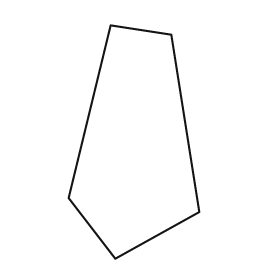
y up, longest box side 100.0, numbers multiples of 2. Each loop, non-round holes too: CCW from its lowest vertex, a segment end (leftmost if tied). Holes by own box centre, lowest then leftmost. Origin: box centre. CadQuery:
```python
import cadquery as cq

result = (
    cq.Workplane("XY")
    .moveTo(-8.0, -50.0)
    .lineTo(28.0, -30.0)
    .lineTo(16.0, 46.0)
    .lineTo(-10.0, 50.0)
    .lineTo(-28.0, -24.0)
    .close()
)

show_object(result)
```